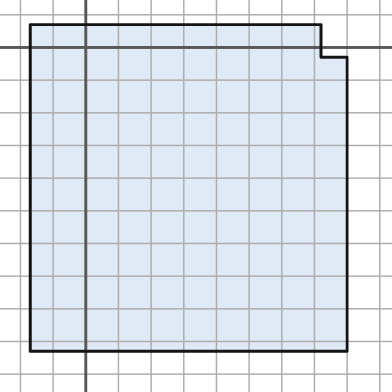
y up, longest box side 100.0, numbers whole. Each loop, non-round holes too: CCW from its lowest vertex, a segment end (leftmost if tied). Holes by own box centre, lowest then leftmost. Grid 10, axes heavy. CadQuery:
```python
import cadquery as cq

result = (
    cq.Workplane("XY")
    .moveTo(-17.0, -93.0)
    .lineTo(80.0, -93.0)
    .lineTo(80.0, -3.0)
    .lineTo(72.0, -3.0)
    .lineTo(72.0, 7.0)
    .lineTo(-17.0, 7.0)
    .close()
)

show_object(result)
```